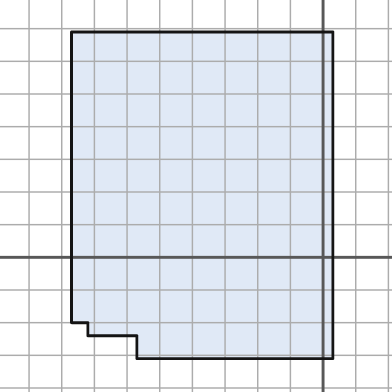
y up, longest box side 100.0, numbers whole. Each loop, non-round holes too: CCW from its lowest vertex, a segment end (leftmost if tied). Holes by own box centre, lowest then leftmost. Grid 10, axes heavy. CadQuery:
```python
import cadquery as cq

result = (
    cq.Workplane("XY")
    .moveTo(-57.0, -31.0)
    .lineTo(3.0, -31.0)
    .lineTo(3.0, 69.0)
    .lineTo(-77.0, 69.0)
    .lineTo(-77.0, -20.0)
    .lineTo(-72.0, -20.0)
    .lineTo(-72.0, -24.0)
    .lineTo(-57.0, -24.0)
    .close()
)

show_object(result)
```